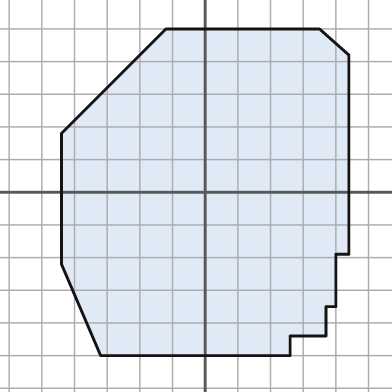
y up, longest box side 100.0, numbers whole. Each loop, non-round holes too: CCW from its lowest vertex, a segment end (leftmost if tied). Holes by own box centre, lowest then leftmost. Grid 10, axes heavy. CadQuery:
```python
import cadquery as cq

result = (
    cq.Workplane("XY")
    .moveTo(-32.0, -50.0)
    .lineTo(26.0, -50.0)
    .lineTo(26.0, -44.0)
    .lineTo(37.0, -44.0)
    .lineTo(37.0, -35.0)
    .lineTo(40.0, -35.0)
    .lineTo(40.0, -19.0)
    .lineTo(44.0, -19.0)
    .lineTo(44.0, 42.0)
    .lineTo(35.0, 50.0)
    .lineTo(-12.0, 50.0)
    .lineTo(-44.0, 18.0)
    .lineTo(-44.0, -22.0)
    .close()
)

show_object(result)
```